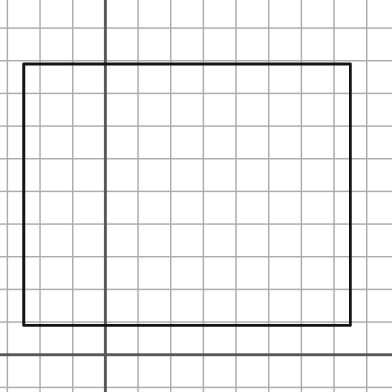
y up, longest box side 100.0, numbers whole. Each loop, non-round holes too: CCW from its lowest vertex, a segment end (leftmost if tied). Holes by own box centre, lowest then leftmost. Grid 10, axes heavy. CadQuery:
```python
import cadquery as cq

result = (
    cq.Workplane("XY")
    .moveTo(-25.0, 9.0)
    .lineTo(75.0, 9.0)
    .lineTo(75.0, 89.0)
    .lineTo(-25.0, 89.0)
    .close()
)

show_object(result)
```